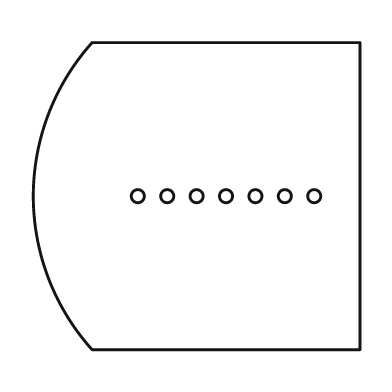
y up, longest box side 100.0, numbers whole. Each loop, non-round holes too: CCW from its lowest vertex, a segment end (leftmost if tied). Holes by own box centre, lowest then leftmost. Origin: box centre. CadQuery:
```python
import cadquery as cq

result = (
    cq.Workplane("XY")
    .moveTo(-32.0, -47.0)
    .lineTo(50.0, -47.0)
    .lineTo(50.0, 47.0)
    .lineTo(-32.0, 47.0)
    .threePointArc((-50.0, 0.0), (-32.0, -47.0))
    .close()
    .moveTo(-18.0, 0.0)
    .circle(2.0)
    .moveTo(-9.0, 0.0)
    .circle(2.0)
    .moveTo(0.0, 0.0)
    .circle(2.0)
    .moveTo(9.0, 0.0)
    .circle(2.0)
    .moveTo(18.0, 0.0)
    .circle(2.0)
    .moveTo(27.0, 0.0)
    .circle(2.0)
    .moveTo(36.0, 0.0)
    .circle(2.0)
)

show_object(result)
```